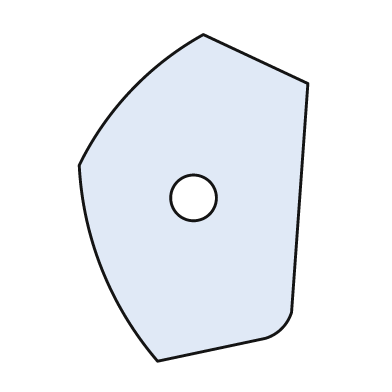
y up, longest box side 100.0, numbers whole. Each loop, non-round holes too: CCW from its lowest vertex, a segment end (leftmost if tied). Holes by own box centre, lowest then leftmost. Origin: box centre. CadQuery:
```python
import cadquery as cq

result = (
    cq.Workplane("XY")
    .moveTo(-11.0, -50.0)
    .lineTo(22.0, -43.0)
    .threePointArc((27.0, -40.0), (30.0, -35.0))
    .lineTo(35.0, 35.0)
    .lineTo(3.0, 50.0)
    .threePointArc((-19.0, 33.0), (-35.0, 10.0))
    .threePointArc((-28.0, -22.0), (-11.0, -50.0))
    .close()
    .moveTo(0.0, 0.0)
    .circle(7.0)
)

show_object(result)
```